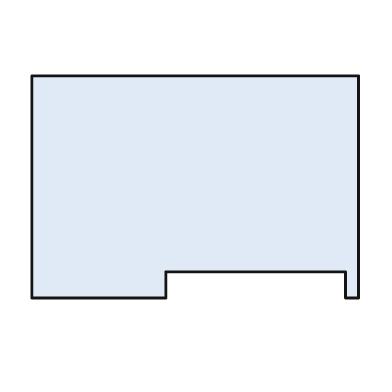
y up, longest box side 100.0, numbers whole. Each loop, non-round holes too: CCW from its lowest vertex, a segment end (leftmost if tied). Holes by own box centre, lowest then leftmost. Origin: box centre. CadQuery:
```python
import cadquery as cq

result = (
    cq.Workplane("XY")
    .moveTo(-50.0, -34.0)
    .lineTo(-9.0, -34.0)
    .lineTo(-9.0, -26.0)
    .lineTo(46.0, -26.0)
    .lineTo(46.0, -34.0)
    .lineTo(50.0, -34.0)
    .lineTo(50.0, 34.0)
    .lineTo(-50.0, 34.0)
    .close()
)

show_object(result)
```